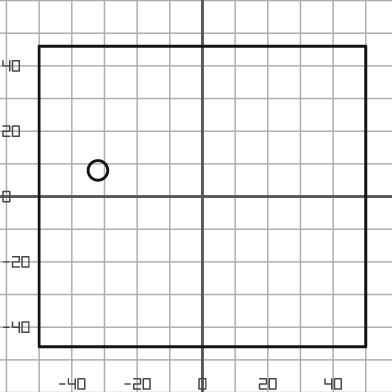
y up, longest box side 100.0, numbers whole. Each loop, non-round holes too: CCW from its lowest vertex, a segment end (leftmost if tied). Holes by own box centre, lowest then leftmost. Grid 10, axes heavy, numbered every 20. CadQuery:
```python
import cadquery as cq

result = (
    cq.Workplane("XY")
    .moveTo(-50.0, -46.0)
    .lineTo(50.0, -46.0)
    .lineTo(50.0, 46.0)
    .lineTo(-50.0, 46.0)
    .close()
    .moveTo(-32.0, 8.0)
    .circle(3.0)
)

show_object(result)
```